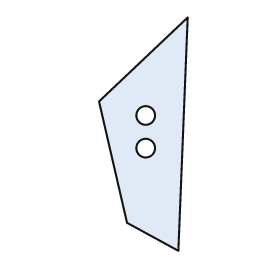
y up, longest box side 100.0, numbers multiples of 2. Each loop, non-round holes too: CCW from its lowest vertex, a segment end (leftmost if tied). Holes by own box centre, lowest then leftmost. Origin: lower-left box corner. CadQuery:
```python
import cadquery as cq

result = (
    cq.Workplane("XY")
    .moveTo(34.0, 0.0)
    .lineTo(38.0, 100.0)
    .lineTo(0.0, 64.0)
    .lineTo(12.0, 12.0)
    .close()
    .moveTo(20.0, 44.0)
    .circle(4.0)
    .moveTo(20.0, 58.0)
    .circle(4.0)
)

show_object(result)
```